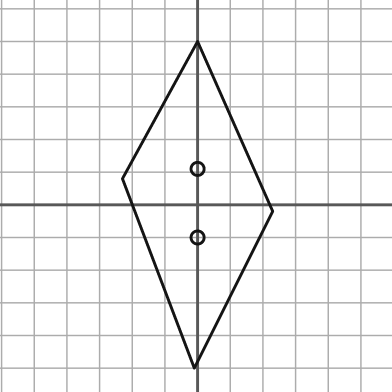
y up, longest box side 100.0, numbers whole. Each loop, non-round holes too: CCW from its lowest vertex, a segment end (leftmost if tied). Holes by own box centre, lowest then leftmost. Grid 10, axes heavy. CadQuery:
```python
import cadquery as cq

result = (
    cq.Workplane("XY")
    .moveTo(-1.0, -50.0)
    .lineTo(23.0, -2.0)
    .lineTo(0.0, 50.0)
    .lineTo(-23.0, 8.0)
    .close()
    .moveTo(0.0, -10.0)
    .circle(2.0)
    .moveTo(0.0, 11.0)
    .circle(2.0)
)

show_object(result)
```